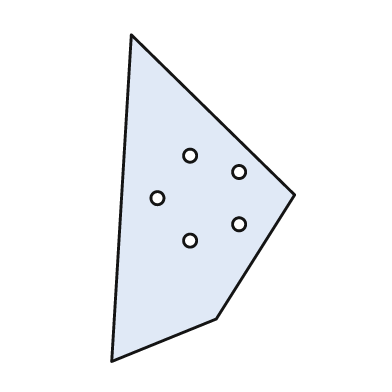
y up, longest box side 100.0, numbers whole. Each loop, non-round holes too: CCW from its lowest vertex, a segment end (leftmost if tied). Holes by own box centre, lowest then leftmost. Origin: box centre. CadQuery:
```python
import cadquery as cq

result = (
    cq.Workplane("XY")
    .moveTo(-28.0, -50.0)
    .lineTo(4.0, -37.0)
    .lineTo(28.0, 1.0)
    .lineTo(-22.0, 50.0)
    .close()
    .moveTo(-4.0, -13.0)
    .circle(2.0)
    .moveTo(11.0, -8.0)
    .circle(2.0)
    .moveTo(-14.0, 0.0)
    .circle(2.0)
    .moveTo(11.0, 8.0)
    .circle(2.0)
    .moveTo(-4.0, 13.0)
    .circle(2.0)
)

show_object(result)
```